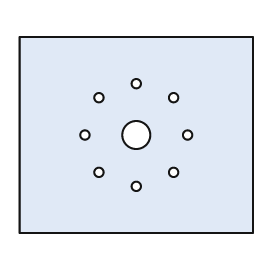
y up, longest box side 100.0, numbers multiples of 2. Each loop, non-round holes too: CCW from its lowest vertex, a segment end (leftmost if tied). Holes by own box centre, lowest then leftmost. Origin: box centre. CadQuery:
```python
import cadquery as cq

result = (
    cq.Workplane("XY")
    .moveTo(-50.0, -42.0)
    .lineTo(50.0, -42.0)
    .lineTo(50.0, 42.0)
    .lineTo(-50.0, 42.0)
    .close()
    .moveTo(0.0, -22.0)
    .circle(2.0)
    .moveTo(-16.0, -16.0)
    .circle(2.0)
    .moveTo(16.0, -16.0)
    .circle(2.0)
    .moveTo(-22.0, 0.0)
    .circle(2.0)
    .moveTo(0.0, 0.0)
    .circle(6.0)
    .moveTo(22.0, 0.0)
    .circle(2.0)
    .moveTo(-16.0, 16.0)
    .circle(2.0)
    .moveTo(16.0, 16.0)
    .circle(2.0)
    .moveTo(0.0, 22.0)
    .circle(2.0)
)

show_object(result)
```